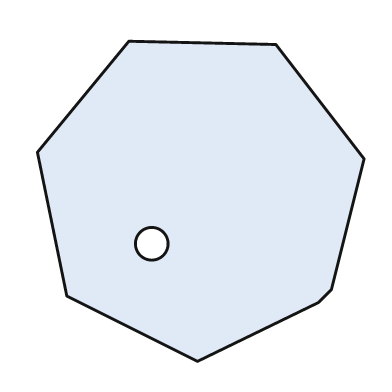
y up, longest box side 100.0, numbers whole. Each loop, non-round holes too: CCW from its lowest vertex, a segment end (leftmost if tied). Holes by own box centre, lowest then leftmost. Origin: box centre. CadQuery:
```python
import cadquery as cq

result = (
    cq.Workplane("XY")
    .moveTo(-1.0, -49.0)
    .lineTo(36.0, -31.0)
    .lineTo(40.0, -27.0)
    .lineTo(50.0, 13.0)
    .lineTo(23.0, 48.0)
    .lineTo(-22.0, 49.0)
    .lineTo(-50.0, 15.0)
    .lineTo(-41.0, -29.0)
    .close()
    .moveTo(-15.0, -13.0)
    .circle(5.0)
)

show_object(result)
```